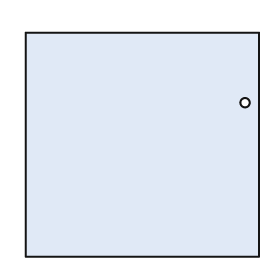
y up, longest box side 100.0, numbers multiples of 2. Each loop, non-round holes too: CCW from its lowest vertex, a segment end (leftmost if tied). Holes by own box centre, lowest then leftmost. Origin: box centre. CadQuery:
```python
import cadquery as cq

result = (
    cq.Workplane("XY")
    .moveTo(-50.0, -48.0)
    .lineTo(50.0, -48.0)
    .lineTo(50.0, 48.0)
    .lineTo(-50.0, 48.0)
    .close()
    .moveTo(44.0, 18.0)
    .circle(2.0)
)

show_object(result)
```